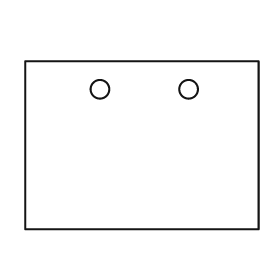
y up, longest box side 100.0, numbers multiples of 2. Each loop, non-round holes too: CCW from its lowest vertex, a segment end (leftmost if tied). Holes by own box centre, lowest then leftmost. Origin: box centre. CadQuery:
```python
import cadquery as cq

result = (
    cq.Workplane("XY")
    .moveTo(-50.0, -36.0)
    .lineTo(50.0, -36.0)
    .lineTo(50.0, 36.0)
    .lineTo(-50.0, 36.0)
    .close()
    .moveTo(-18.0, 24.0)
    .circle(4.0)
    .moveTo(20.0, 24.0)
    .circle(4.0)
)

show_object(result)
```